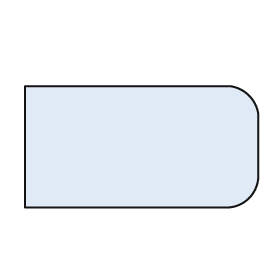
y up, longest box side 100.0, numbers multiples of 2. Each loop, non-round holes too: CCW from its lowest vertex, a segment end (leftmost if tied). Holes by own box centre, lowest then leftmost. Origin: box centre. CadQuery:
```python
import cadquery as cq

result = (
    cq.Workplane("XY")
    .moveTo(-50.0, -26.0)
    .lineTo(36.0, -26.0)
    .threePointArc((46.0, -22.0), (50.0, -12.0))
    .lineTo(50.0, 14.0)
    .threePointArc((46.0, 22.0), (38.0, 26.0))
    .lineTo(-50.0, 26.0)
    .close()
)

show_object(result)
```